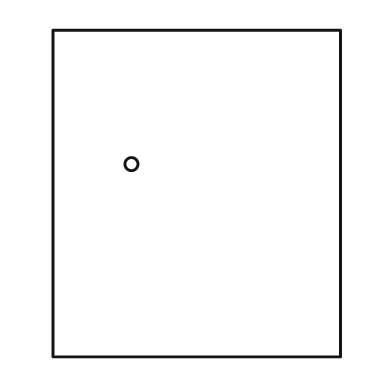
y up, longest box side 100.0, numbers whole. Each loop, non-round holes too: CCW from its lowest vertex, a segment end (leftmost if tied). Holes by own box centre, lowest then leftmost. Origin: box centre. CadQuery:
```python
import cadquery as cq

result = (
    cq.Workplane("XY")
    .moveTo(-44.0, -50.0)
    .lineTo(44.0, -50.0)
    .lineTo(44.0, 50.0)
    .lineTo(-44.0, 50.0)
    .close()
    .moveTo(-20.0, 9.0)
    .circle(2.0)
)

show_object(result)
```